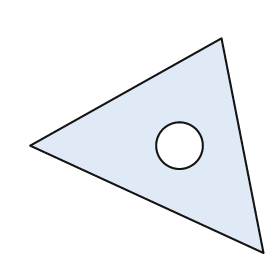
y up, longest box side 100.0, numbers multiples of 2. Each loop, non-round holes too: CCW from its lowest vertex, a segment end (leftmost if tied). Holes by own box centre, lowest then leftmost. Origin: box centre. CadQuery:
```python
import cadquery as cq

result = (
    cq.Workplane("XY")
    .moveTo(50.0, -46.0)
    .lineTo(32.0, 46.0)
    .lineTo(-50.0, 0.0)
    .close()
    .moveTo(14.0, 0.0)
    .circle(10.0)
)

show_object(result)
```